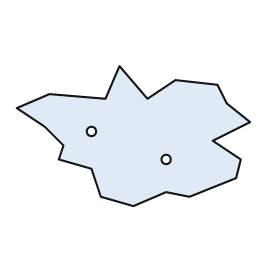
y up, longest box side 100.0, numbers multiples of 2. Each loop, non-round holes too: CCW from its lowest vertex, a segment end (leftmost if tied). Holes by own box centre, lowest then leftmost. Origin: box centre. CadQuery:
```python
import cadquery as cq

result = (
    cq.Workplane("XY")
    .moveTo(0.0, -30.0)
    .lineTo(14.0, -24.0)
    .lineTo(24.0, -26.0)
    .lineTo(44.0, -18.0)
    .lineTo(46.0, -10.0)
    .lineTo(34.0, -2.0)
    .lineTo(50.0, 6.0)
    .lineTo(40.0, 14.0)
    .lineTo(36.0, 22.0)
    .lineTo(18.0, 24.0)
    .lineTo(6.0, 16.0)
    .lineTo(-6.0, 30.0)
    .lineTo(-12.0, 16.0)
    .lineTo(-36.0, 18.0)
    .lineTo(-50.0, 12.0)
    .lineTo(-38.0, 4.0)
    .lineTo(-30.0, -4.0)
    .lineTo(-32.0, -10.0)
    .lineTo(-18.0, -14.0)
    .lineTo(-14.0, -26.0)
    .close()
    .moveTo(14.0, -10.0)
    .circle(2.0)
    .moveTo(-18.0, 2.0)
    .circle(2.0)
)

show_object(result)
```